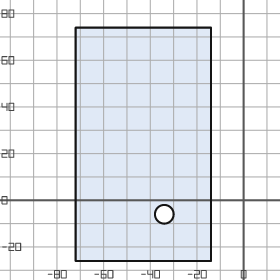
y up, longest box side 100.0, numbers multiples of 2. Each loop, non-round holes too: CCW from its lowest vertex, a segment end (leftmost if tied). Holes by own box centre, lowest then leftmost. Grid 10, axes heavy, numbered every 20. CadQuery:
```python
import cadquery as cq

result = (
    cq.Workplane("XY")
    .moveTo(-72.0, -26.0)
    .lineTo(-14.0, -26.0)
    .lineTo(-14.0, 74.0)
    .lineTo(-72.0, 74.0)
    .close()
    .moveTo(-34.0, -6.0)
    .circle(4.0)
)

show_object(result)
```